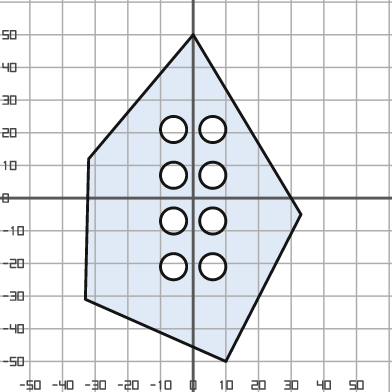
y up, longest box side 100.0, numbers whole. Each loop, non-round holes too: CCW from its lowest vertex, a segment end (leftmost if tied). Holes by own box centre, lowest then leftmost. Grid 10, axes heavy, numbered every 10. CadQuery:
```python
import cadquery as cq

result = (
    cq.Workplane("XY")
    .moveTo(10.0, -50.0)
    .lineTo(33.0, -5.0)
    .lineTo(0.0, 50.0)
    .lineTo(-32.0, 12.0)
    .lineTo(-33.0, -31.0)
    .close()
    .moveTo(-6.0, -21.0)
    .circle(4.0)
    .moveTo(6.0, -21.0)
    .circle(4.0)
    .moveTo(-6.0, -7.0)
    .circle(4.0)
    .moveTo(6.0, -7.0)
    .circle(4.0)
    .moveTo(-6.0, 7.0)
    .circle(4.0)
    .moveTo(6.0, 7.0)
    .circle(4.0)
    .moveTo(-6.0, 21.0)
    .circle(4.0)
    .moveTo(6.0, 21.0)
    .circle(4.0)
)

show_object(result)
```